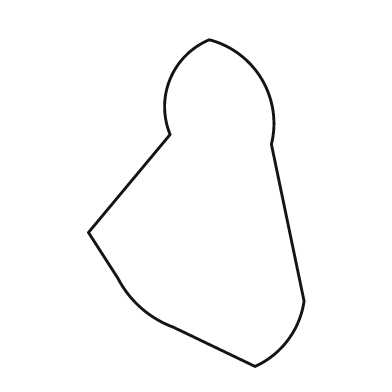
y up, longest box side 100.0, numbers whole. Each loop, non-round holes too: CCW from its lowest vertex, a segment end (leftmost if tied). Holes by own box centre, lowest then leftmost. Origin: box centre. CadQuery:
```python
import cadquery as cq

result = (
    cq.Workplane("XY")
    .moveTo(18.0, -50.0)
    .threePointArc((28.0, -42.0), (33.0, -30.0))
    .lineTo(23.0, 18.0)
    .threePointArc((20.0, 38.0), (4.0, 50.0))
    .threePointArc((-8.0, 38.0), (-8.0, 21.0))
    .lineTo(-33.0, -9.0)
    .lineTo(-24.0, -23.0)
    .threePointArc((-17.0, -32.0), (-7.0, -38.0))
    .close()
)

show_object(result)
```